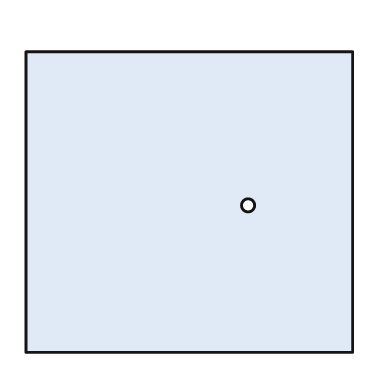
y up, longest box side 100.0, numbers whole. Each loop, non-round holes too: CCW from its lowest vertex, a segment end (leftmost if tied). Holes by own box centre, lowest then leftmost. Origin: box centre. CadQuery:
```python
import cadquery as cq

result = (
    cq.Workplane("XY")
    .moveTo(-50.0, -46.0)
    .lineTo(50.0, -46.0)
    .lineTo(50.0, 46.0)
    .lineTo(-50.0, 46.0)
    .close()
    .moveTo(18.0, -1.0)
    .circle(2.0)
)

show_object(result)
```